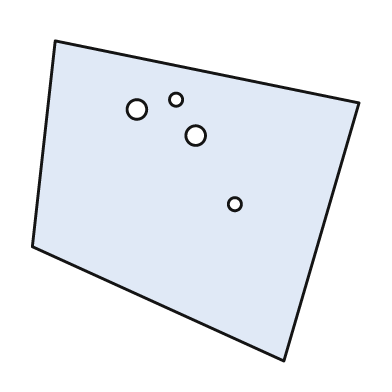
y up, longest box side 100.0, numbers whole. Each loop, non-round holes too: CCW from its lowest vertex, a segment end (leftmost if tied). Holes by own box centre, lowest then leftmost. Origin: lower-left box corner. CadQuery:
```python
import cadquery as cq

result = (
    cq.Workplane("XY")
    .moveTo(77.0, 0.0)
    .lineTo(100.0, 79.0)
    .lineTo(7.0, 98.0)
    .lineTo(0.0, 35.0)
    .close()
    .moveTo(62.0, 48.0)
    .circle(2.0)
    .moveTo(50.0, 69.0)
    .circle(3.0)
    .moveTo(32.0, 77.0)
    .circle(3.0)
    .moveTo(44.0, 80.0)
    .circle(2.0)
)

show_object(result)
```